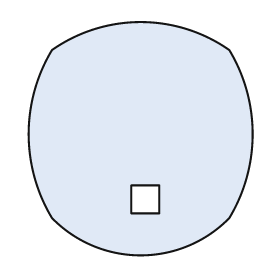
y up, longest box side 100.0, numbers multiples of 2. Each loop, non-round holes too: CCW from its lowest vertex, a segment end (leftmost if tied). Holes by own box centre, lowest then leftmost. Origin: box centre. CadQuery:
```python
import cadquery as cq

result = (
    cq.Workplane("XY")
    .moveTo(-38.0, -34.0)
    .threePointArc((0.0, -50.0), (38.0, -34.0))
    .threePointArc((48.0, 2.0), (38.0, 38.0))
    .threePointArc((0.0, 50.0), (-38.0, 38.0))
    .threePointArc((-48.0, 2.0), (-38.0, -34.0))
    .close()
    .moveTo(-4.0, -32.0)
    .lineTo(8.0, -32.0)
    .lineTo(8.0, -20.0)
    .lineTo(-4.0, -20.0)
    .close()
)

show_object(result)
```